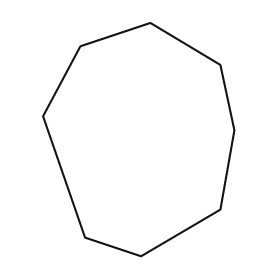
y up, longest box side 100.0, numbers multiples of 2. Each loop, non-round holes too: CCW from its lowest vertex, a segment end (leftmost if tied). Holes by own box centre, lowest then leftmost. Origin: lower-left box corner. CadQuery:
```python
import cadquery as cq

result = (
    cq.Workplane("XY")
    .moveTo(42.0, 0.0)
    .lineTo(76.0, 20.0)
    .lineTo(82.0, 54.0)
    .lineTo(76.0, 82.0)
    .lineTo(46.0, 100.0)
    .lineTo(16.0, 90.0)
    .lineTo(0.0, 60.0)
    .lineTo(18.0, 8.0)
    .close()
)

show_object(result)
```